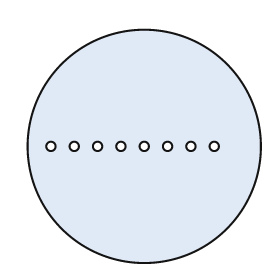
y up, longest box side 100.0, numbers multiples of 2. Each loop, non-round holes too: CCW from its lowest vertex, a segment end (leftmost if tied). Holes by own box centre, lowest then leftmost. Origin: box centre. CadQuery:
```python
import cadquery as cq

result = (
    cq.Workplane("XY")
    .moveTo(0.0, 0.0)
    .circle(50.0)
    .moveTo(-40.0, 0.0)
    .circle(2.0)
    .moveTo(-30.0, 0.0)
    .circle(2.0)
    .moveTo(-20.0, 0.0)
    .circle(2.0)
    .moveTo(-10.0, 0.0)
    .circle(2.0)
    .moveTo(0.0, 0.0)
    .circle(2.0)
    .moveTo(10.0, 0.0)
    .circle(2.0)
    .moveTo(20.0, 0.0)
    .circle(2.0)
    .moveTo(30.0, 0.0)
    .circle(2.0)
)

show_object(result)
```